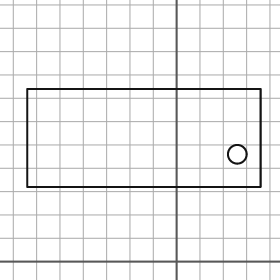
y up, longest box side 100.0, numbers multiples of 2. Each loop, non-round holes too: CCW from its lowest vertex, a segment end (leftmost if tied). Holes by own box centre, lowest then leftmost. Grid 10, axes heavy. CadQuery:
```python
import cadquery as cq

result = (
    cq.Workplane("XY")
    .moveTo(-64.0, 32.0)
    .lineTo(36.0, 32.0)
    .lineTo(36.0, 74.0)
    .lineTo(-64.0, 74.0)
    .close()
    .moveTo(26.0, 46.0)
    .circle(4.0)
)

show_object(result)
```